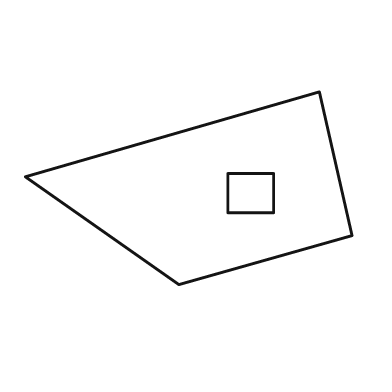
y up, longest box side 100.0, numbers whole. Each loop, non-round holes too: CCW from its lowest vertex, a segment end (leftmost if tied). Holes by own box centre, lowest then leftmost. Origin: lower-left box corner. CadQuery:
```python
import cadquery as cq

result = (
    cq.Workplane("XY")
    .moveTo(47.0, 0.0)
    .lineTo(100.0, 15.0)
    .lineTo(90.0, 59.0)
    .lineTo(0.0, 33.0)
    .close()
    .moveTo(62.0, 22.0)
    .lineTo(76.0, 22.0)
    .lineTo(76.0, 34.0)
    .lineTo(62.0, 34.0)
    .close()
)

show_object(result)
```